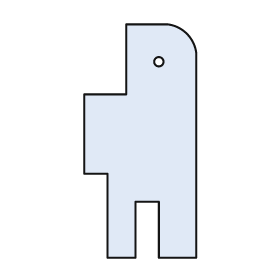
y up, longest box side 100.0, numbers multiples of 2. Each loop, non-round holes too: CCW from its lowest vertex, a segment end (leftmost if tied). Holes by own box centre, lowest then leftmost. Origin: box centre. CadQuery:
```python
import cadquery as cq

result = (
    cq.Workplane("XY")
    .moveTo(-14.0, -50.0)
    .lineTo(-2.0, -50.0)
    .lineTo(-2.0, -26.0)
    .lineTo(8.0, -26.0)
    .lineTo(8.0, -50.0)
    .lineTo(24.0, -50.0)
    .lineTo(24.0, 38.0)
    .threePointArc((20.0, 46.0), (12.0, 50.0))
    .lineTo(-6.0, 50.0)
    .lineTo(-6.0, 20.0)
    .lineTo(-24.0, 20.0)
    .lineTo(-24.0, -14.0)
    .lineTo(-14.0, -14.0)
    .close()
    .moveTo(8.0, 34.0)
    .circle(2.0)
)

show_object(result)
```